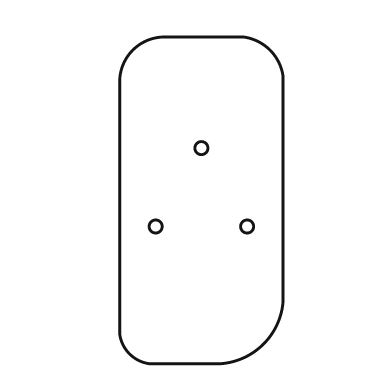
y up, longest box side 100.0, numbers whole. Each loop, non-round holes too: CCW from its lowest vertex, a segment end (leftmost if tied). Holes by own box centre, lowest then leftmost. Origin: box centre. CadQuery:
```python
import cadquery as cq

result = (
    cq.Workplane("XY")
    .moveTo(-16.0, -50.0)
    .lineTo(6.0, -50.0)
    .threePointArc((19.0, -44.0), (25.0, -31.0))
    .lineTo(25.0, 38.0)
    .threePointArc((21.0, 46.0), (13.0, 50.0))
    .lineTo(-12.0, 50.0)
    .threePointArc((-21.0, 46.0), (-25.0, 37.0))
    .lineTo(-25.0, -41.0)
    .threePointArc((-22.0, -47.0), (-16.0, -50.0))
    .close()
    .moveTo(-14.0, -8.0)
    .circle(2.0)
    .moveTo(14.0, -8.0)
    .circle(2.0)
    .moveTo(0.0, 16.0)
    .circle(2.0)
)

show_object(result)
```